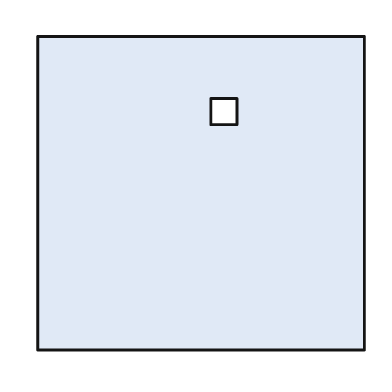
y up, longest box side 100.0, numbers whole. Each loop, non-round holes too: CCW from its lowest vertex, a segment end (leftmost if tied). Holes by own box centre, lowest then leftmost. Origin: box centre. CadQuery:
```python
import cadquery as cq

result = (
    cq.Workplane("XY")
    .moveTo(-50.0, -48.0)
    .lineTo(50.0, -48.0)
    .lineTo(50.0, 48.0)
    .lineTo(-50.0, 48.0)
    .close()
    .moveTo(3.0, 21.0)
    .lineTo(11.0, 21.0)
    .lineTo(11.0, 29.0)
    .lineTo(3.0, 29.0)
    .close()
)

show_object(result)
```